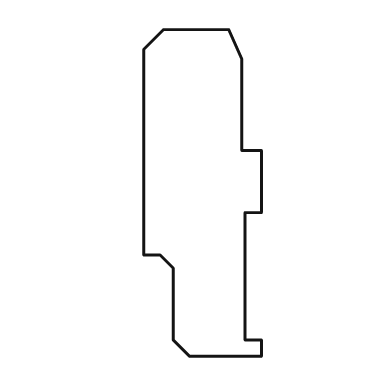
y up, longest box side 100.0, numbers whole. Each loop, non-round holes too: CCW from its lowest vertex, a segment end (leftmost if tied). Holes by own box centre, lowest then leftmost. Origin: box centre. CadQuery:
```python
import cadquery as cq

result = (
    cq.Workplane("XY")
    .moveTo(-4.0, -50.0)
    .lineTo(18.0, -50.0)
    .lineTo(18.0, -45.0)
    .lineTo(13.0, -45.0)
    .lineTo(13.0, -6.0)
    .lineTo(18.0, -6.0)
    .lineTo(18.0, 13.0)
    .lineTo(12.0, 13.0)
    .lineTo(12.0, 41.0)
    .lineTo(8.0, 50.0)
    .lineTo(-12.0, 50.0)
    .lineTo(-18.0, 44.0)
    .lineTo(-18.0, -19.0)
    .lineTo(-13.0, -19.0)
    .lineTo(-9.0, -23.0)
    .lineTo(-9.0, -45.0)
    .close()
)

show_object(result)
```